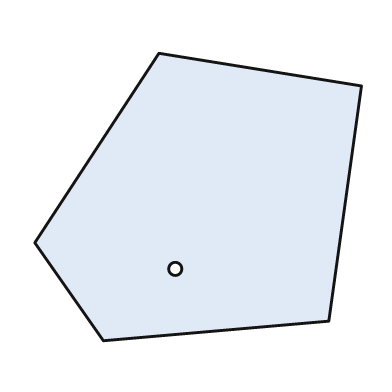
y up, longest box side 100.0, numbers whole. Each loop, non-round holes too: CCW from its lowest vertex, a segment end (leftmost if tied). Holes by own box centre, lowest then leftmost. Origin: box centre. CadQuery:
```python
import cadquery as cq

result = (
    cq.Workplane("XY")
    .moveTo(-29.0, -44.0)
    .lineTo(40.0, -38.0)
    .lineTo(50.0, 34.0)
    .lineTo(-12.0, 44.0)
    .lineTo(-50.0, -14.0)
    .close()
    .moveTo(-7.0, -22.0)
    .circle(2.0)
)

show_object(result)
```